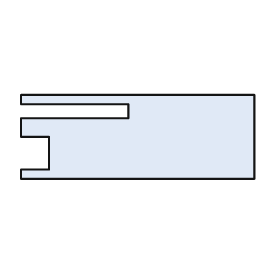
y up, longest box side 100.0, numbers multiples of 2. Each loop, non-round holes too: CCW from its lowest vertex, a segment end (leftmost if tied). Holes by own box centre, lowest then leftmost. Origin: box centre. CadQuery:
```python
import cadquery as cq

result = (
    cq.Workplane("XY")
    .moveTo(-50.0, -18.0)
    .lineTo(50.0, -18.0)
    .lineTo(50.0, 18.0)
    .lineTo(-50.0, 18.0)
    .lineTo(-50.0, 14.0)
    .lineTo(-4.0, 14.0)
    .lineTo(-4.0, 8.0)
    .lineTo(-50.0, 8.0)
    .lineTo(-50.0, 0.0)
    .lineTo(-38.0, 0.0)
    .lineTo(-38.0, -14.0)
    .lineTo(-50.0, -14.0)
    .close()
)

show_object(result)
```